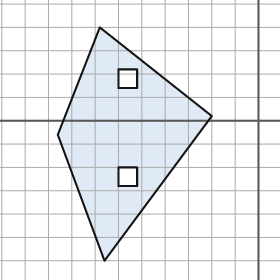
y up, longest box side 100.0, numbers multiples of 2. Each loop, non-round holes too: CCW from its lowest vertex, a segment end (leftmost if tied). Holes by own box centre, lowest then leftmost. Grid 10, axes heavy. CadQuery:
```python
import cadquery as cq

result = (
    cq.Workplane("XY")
    .moveTo(-66.0, -60.0)
    .lineTo(-20.0, 2.0)
    .lineTo(-68.0, 40.0)
    .lineTo(-86.0, -6.0)
    .close()
    .moveTo(-60.0, -28.0)
    .lineTo(-52.0, -28.0)
    .lineTo(-52.0, -20.0)
    .lineTo(-60.0, -20.0)
    .close()
    .moveTo(-60.0, 14.0)
    .lineTo(-52.0, 14.0)
    .lineTo(-52.0, 22.0)
    .lineTo(-60.0, 22.0)
    .close()
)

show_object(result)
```